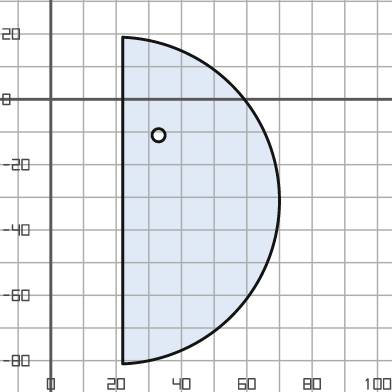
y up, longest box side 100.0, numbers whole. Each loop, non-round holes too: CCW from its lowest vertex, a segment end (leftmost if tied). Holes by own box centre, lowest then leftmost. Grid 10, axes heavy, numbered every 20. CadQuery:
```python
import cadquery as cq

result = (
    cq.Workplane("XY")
    .moveTo(22.0, -81.0)
    .threePointArc((70.0, -31.0), (22.0, 19.0))
    .close()
    .moveTo(33.0, -11.0)
    .circle(2.0)
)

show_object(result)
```